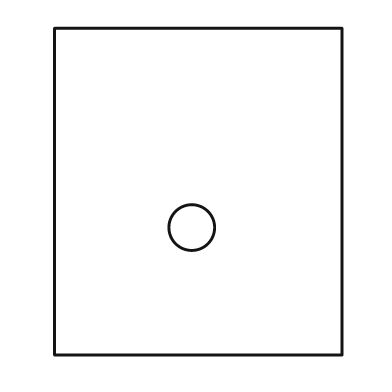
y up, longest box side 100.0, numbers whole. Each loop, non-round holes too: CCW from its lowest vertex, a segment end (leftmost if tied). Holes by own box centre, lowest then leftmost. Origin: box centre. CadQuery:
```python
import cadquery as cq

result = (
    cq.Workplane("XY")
    .moveTo(-44.0, -50.0)
    .lineTo(44.0, -50.0)
    .lineTo(44.0, 50.0)
    .lineTo(-44.0, 50.0)
    .close()
    .moveTo(-2.0, -11.0)
    .circle(7.0)
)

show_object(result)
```